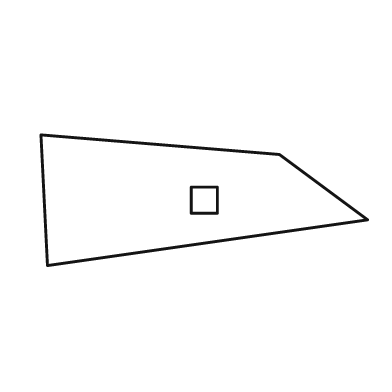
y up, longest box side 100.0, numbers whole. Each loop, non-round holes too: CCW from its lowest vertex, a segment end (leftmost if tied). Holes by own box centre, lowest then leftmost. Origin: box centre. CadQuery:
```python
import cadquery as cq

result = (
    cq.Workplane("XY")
    .moveTo(-48.0, -20.0)
    .lineTo(50.0, -6.0)
    .lineTo(23.0, 14.0)
    .lineTo(-50.0, 20.0)
    .close()
    .moveTo(-4.0, -4.0)
    .lineTo(4.0, -4.0)
    .lineTo(4.0, 4.0)
    .lineTo(-4.0, 4.0)
    .close()
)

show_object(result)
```